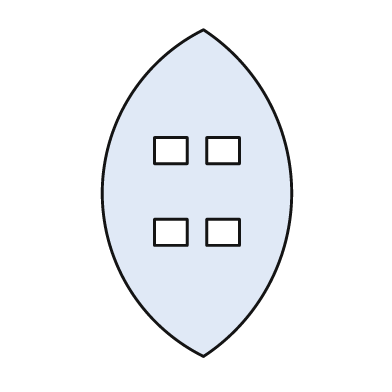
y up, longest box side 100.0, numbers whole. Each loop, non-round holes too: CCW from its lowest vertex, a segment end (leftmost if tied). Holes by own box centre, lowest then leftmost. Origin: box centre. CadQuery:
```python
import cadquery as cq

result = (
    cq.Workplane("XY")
    .moveTo(2.0, -50.0)
    .threePointArc((29.0, 0.0), (2.0, 50.0))
    .threePointArc((-29.0, 0.0), (2.0, -50.0))
    .close()
    .moveTo(-13.0, -16.0)
    .lineTo(-3.0, -16.0)
    .lineTo(-3.0, -8.0)
    .lineTo(-13.0, -8.0)
    .close()
    .moveTo(3.0, -16.0)
    .lineTo(13.0, -16.0)
    .lineTo(13.0, -8.0)
    .lineTo(3.0, -8.0)
    .close()
    .moveTo(-13.0, 9.0)
    .lineTo(-3.0, 9.0)
    .lineTo(-3.0, 17.0)
    .lineTo(-13.0, 17.0)
    .close()
    .moveTo(3.0, 9.0)
    .lineTo(13.0, 9.0)
    .lineTo(13.0, 17.0)
    .lineTo(3.0, 17.0)
    .close()
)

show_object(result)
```